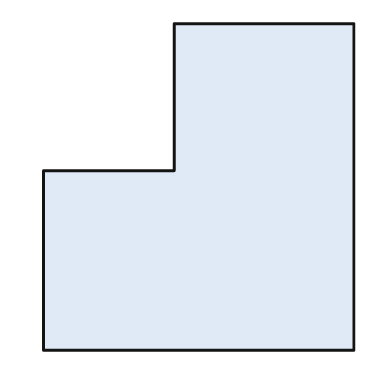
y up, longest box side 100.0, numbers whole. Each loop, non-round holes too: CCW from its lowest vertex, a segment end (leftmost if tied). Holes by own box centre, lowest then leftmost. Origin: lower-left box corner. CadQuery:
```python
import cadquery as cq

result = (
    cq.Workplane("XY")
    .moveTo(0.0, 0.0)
    .lineTo(95.0, 0.0)
    .lineTo(95.0, 100.0)
    .lineTo(40.0, 100.0)
    .lineTo(40.0, 55.0)
    .lineTo(0.0, 55.0)
    .close()
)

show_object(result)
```